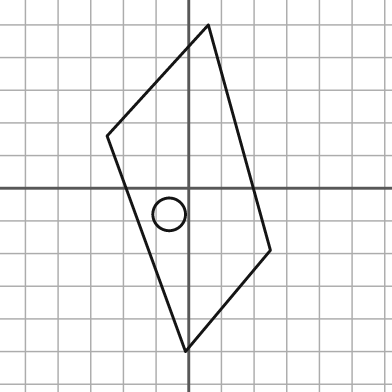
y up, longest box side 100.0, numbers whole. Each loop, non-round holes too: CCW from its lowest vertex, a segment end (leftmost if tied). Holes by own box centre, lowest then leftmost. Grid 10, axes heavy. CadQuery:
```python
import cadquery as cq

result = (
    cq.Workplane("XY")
    .moveTo(-1.0, -50.0)
    .lineTo(25.0, -19.0)
    .lineTo(6.0, 50.0)
    .lineTo(-25.0, 16.0)
    .close()
    .moveTo(-6.0, -8.0)
    .circle(5.0)
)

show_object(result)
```